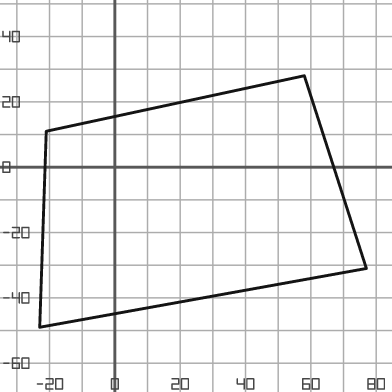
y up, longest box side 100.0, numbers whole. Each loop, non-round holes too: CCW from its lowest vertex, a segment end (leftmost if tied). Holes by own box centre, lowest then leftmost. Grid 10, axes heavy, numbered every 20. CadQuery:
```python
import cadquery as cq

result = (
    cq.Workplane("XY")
    .moveTo(-23.0, -49.0)
    .lineTo(77.0, -31.0)
    .lineTo(58.0, 28.0)
    .lineTo(-21.0, 11.0)
    .close()
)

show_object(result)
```